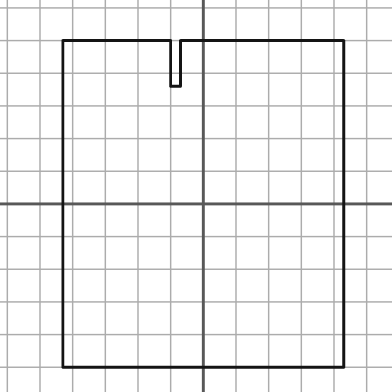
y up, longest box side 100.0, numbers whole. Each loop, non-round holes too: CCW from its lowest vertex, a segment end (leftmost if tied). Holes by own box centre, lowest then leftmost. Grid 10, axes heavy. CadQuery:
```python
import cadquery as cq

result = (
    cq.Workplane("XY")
    .moveTo(-43.0, -50.0)
    .lineTo(43.0, -50.0)
    .lineTo(43.0, 50.0)
    .lineTo(-7.0, 50.0)
    .lineTo(-7.0, 36.0)
    .lineTo(-10.0, 36.0)
    .lineTo(-10.0, 50.0)
    .lineTo(-43.0, 50.0)
    .close()
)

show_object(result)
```